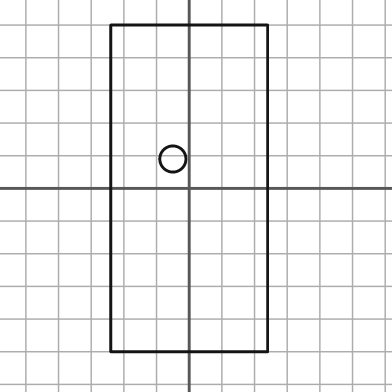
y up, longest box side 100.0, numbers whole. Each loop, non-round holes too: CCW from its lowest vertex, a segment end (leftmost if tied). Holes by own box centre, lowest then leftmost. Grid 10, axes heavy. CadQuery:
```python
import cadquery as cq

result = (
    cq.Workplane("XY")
    .moveTo(-24.0, -50.0)
    .lineTo(24.0, -50.0)
    .lineTo(24.0, 50.0)
    .lineTo(-24.0, 50.0)
    .close()
    .moveTo(-5.0, 9.0)
    .circle(4.0)
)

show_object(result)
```